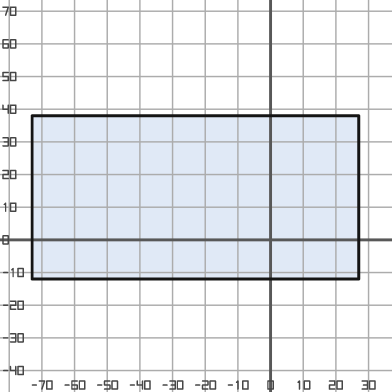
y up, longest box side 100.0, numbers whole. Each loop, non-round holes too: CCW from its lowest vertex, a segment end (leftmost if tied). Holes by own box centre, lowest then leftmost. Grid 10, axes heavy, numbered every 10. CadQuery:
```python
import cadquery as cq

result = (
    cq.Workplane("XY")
    .moveTo(-73.0, -12.0)
    .lineTo(27.0, -12.0)
    .lineTo(27.0, 38.0)
    .lineTo(-73.0, 38.0)
    .close()
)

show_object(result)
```